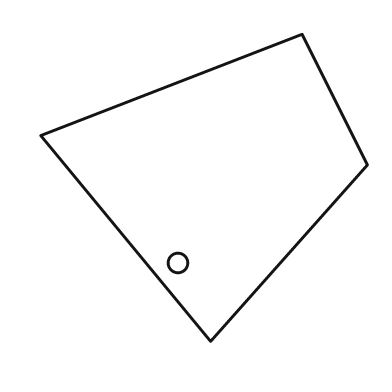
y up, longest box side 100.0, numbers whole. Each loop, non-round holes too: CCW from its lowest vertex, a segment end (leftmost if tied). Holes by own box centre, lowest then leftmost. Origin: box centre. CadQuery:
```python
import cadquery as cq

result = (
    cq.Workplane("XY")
    .moveTo(2.0, -47.0)
    .lineTo(50.0, 7.0)
    .lineTo(30.0, 47.0)
    .lineTo(-50.0, 16.0)
    .close()
    .moveTo(-8.0, -23.0)
    .circle(3.0)
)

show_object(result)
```